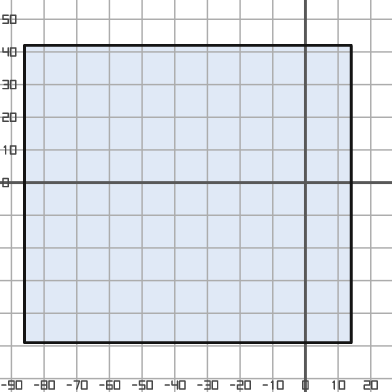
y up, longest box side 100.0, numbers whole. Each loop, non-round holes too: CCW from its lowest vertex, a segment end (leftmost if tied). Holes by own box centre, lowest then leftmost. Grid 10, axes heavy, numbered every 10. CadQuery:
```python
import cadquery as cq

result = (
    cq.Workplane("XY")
    .moveTo(-86.0, -49.0)
    .lineTo(14.0, -49.0)
    .lineTo(14.0, 42.0)
    .lineTo(-86.0, 42.0)
    .close()
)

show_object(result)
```